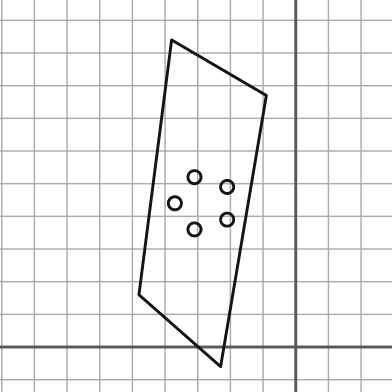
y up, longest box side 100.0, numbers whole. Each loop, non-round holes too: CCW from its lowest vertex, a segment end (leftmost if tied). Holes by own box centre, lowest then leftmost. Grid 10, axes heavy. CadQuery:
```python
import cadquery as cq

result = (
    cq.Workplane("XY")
    .moveTo(-23.0, -6.0)
    .lineTo(-9.0, 77.0)
    .lineTo(-38.0, 94.0)
    .lineTo(-48.0, 16.0)
    .close()
    .moveTo(-31.0, 36.0)
    .circle(2.0)
    .moveTo(-21.0, 39.0)
    .circle(2.0)
    .moveTo(-37.0, 44.0)
    .circle(2.0)
    .moveTo(-21.0, 49.0)
    .circle(2.0)
    .moveTo(-31.0, 52.0)
    .circle(2.0)
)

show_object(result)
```